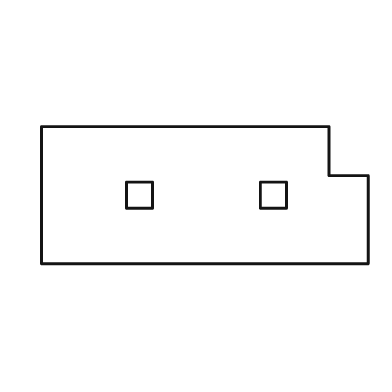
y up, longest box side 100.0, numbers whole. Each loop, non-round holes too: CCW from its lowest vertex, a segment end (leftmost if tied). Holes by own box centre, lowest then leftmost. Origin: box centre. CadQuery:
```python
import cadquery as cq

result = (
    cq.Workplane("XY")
    .moveTo(-50.0, -21.0)
    .lineTo(50.0, -21.0)
    .lineTo(50.0, 6.0)
    .lineTo(38.0, 6.0)
    .lineTo(38.0, 21.0)
    .lineTo(-50.0, 21.0)
    .close()
    .moveTo(-24.0, -4.0)
    .lineTo(-16.0, -4.0)
    .lineTo(-16.0, 4.0)
    .lineTo(-24.0, 4.0)
    .close()
    .moveTo(17.0, -4.0)
    .lineTo(25.0, -4.0)
    .lineTo(25.0, 4.0)
    .lineTo(17.0, 4.0)
    .close()
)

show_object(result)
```